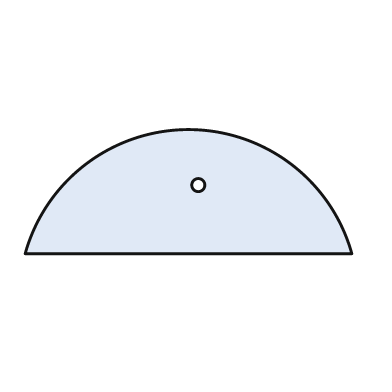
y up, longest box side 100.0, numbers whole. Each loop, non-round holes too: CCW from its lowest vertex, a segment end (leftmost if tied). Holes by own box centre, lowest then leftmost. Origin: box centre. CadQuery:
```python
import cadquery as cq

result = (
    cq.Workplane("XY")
    .moveTo(-50.0, -19.0)
    .lineTo(50.0, -19.0)
    .threePointArc((0.0, 19.0), (-50.0, -19.0))
    .close()
    .moveTo(3.0, 2.0)
    .circle(2.0)
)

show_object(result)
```